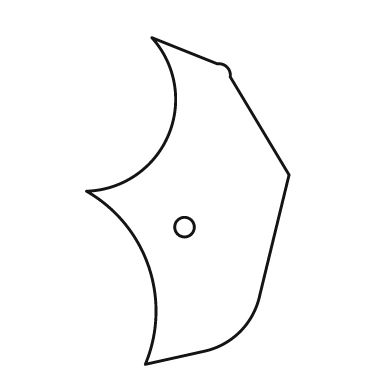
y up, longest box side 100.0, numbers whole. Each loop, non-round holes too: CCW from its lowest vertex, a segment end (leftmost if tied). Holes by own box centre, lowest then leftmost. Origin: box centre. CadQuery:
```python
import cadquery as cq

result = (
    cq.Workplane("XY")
    .moveTo(-13.0, -50.0)
    .lineTo(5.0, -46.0)
    .threePointArc((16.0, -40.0), (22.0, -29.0))
    .lineTo(31.0, 8.0)
    .lineTo(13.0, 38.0)
    .threePointArc((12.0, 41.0), (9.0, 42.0))
    .lineTo(-11.0, 50.0)
    .threePointArc((-6.0, 20.0), (-31.0, 3.0))
    .threePointArc((-12.0, -20.0), (-13.0, -50.0))
    .close()
    .moveTo(-1.0, -8.0)
    .circle(3.0)
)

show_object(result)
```